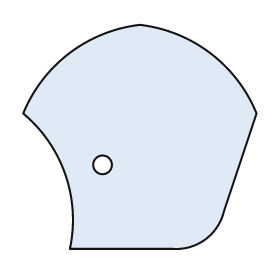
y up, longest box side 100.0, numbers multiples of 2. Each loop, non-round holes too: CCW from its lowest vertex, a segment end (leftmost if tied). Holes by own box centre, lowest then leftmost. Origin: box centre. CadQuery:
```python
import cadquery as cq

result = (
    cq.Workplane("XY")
    .moveTo(-30.0, -48.0)
    .lineTo(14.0, -48.0)
    .threePointArc((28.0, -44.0), (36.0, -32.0))
    .lineTo(50.0, 10.0)
    .threePointArc((30.0, 36.0), (0.0, 48.0))
    .threePointArc((-30.0, 36.0), (-50.0, 10.0))
    .threePointArc((-32.0, -16.0), (-30.0, -48.0))
    .close()
    .moveTo(-16.0, -12.0)
    .circle(4.0)
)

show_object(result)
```